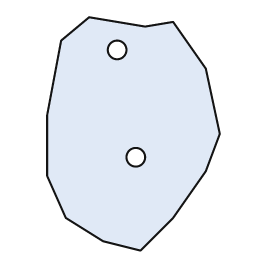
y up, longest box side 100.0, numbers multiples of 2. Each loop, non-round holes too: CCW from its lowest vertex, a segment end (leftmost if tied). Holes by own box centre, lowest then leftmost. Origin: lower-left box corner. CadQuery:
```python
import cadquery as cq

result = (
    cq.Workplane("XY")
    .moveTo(40.0, 0.0)
    .lineTo(54.0, 14.0)
    .lineTo(68.0, 34.0)
    .lineTo(74.0, 50.0)
    .lineTo(68.0, 78.0)
    .lineTo(54.0, 98.0)
    .lineTo(42.0, 96.0)
    .lineTo(18.0, 100.0)
    .lineTo(6.0, 90.0)
    .lineTo(0.0, 58.0)
    .lineTo(0.0, 32.0)
    .lineTo(8.0, 14.0)
    .lineTo(24.0, 4.0)
    .close()
    .moveTo(38.0, 40.0)
    .circle(4.0)
    .moveTo(30.0, 86.0)
    .circle(4.0)
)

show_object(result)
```